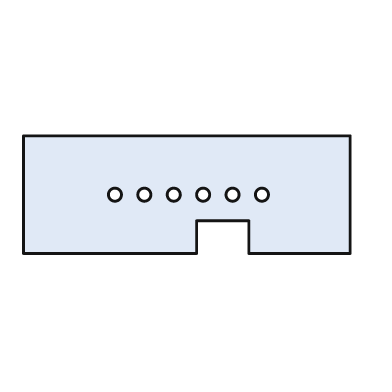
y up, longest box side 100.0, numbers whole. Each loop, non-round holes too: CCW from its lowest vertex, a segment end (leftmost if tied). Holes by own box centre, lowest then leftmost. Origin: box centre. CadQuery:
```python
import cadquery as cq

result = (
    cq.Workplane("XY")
    .moveTo(-50.0, -18.0)
    .lineTo(3.0, -18.0)
    .lineTo(3.0, -8.0)
    .lineTo(19.0, -8.0)
    .lineTo(19.0, -18.0)
    .lineTo(50.0, -18.0)
    .lineTo(50.0, 18.0)
    .lineTo(-50.0, 18.0)
    .close()
    .moveTo(-22.0, 0.0)
    .circle(2.0)
    .moveTo(-13.0, 0.0)
    .circle(2.0)
    .moveTo(-4.0, 0.0)
    .circle(2.0)
    .moveTo(5.0, 0.0)
    .circle(2.0)
    .moveTo(14.0, 0.0)
    .circle(2.0)
    .moveTo(23.0, 0.0)
    .circle(2.0)
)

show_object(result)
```